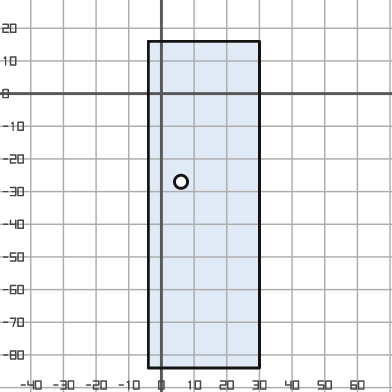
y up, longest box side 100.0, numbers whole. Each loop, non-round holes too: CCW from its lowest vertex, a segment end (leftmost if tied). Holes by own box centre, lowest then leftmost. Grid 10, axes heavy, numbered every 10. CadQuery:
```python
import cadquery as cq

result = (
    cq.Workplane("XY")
    .moveTo(-4.0, -84.0)
    .lineTo(30.0, -84.0)
    .lineTo(30.0, 16.0)
    .lineTo(-4.0, 16.0)
    .close()
    .moveTo(6.0, -27.0)
    .circle(2.0)
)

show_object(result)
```